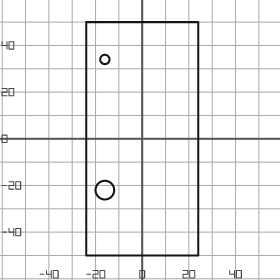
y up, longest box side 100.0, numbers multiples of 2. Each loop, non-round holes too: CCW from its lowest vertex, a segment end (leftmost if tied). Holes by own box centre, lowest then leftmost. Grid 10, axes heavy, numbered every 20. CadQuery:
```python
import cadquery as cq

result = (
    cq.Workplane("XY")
    .moveTo(-24.0, -50.0)
    .lineTo(24.0, -50.0)
    .lineTo(24.0, 50.0)
    .lineTo(-24.0, 50.0)
    .close()
    .moveTo(-16.0, -22.0)
    .circle(4.0)
    .moveTo(-16.0, 34.0)
    .circle(2.0)
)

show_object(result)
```